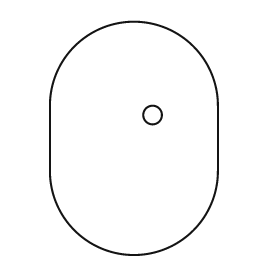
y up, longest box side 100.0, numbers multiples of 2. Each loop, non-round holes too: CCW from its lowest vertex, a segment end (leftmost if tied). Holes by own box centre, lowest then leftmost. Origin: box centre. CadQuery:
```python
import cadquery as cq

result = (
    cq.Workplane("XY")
    .moveTo(-36.0, -14.0)
    .threePointArc((0.0, -50.0), (36.0, -14.0))
    .lineTo(36.0, 14.0)
    .threePointArc((0.0, 50.0), (-36.0, 14.0))
    .close()
    .moveTo(8.0, 10.0)
    .circle(4.0)
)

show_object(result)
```